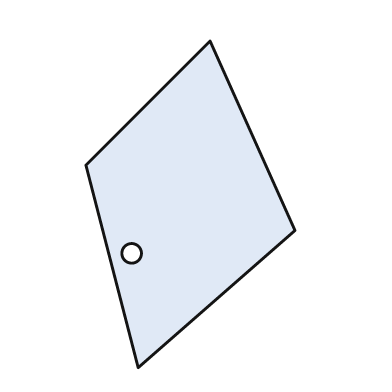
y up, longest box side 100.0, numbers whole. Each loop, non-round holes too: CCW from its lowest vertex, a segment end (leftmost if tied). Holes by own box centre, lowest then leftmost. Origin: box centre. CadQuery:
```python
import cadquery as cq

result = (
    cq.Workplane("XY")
    .moveTo(-16.0, -50.0)
    .lineTo(32.0, -8.0)
    .lineTo(6.0, 50.0)
    .lineTo(-32.0, 12.0)
    .close()
    .moveTo(-18.0, -15.0)
    .circle(3.0)
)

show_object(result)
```